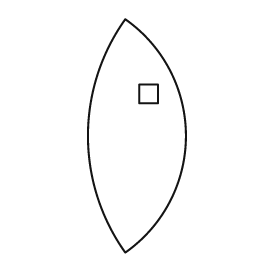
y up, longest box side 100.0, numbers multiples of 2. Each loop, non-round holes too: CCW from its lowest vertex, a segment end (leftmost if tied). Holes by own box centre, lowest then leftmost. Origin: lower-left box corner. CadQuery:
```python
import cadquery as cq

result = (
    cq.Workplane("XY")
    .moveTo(16.0, 0.0)
    .threePointArc((42.0, 50.0), (16.0, 100.0))
    .threePointArc((0.0, 50.0), (16.0, 0.0))
    .close()
    .moveTo(22.0, 64.0)
    .lineTo(30.0, 64.0)
    .lineTo(30.0, 72.0)
    .lineTo(22.0, 72.0)
    .close()
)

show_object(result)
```